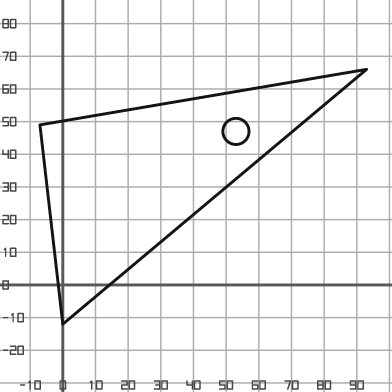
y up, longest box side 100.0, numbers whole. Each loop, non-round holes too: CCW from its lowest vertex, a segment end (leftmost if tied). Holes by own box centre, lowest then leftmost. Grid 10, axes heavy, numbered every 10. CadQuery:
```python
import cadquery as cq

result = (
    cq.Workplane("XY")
    .moveTo(0.0, -12.0)
    .lineTo(93.0, 66.0)
    .lineTo(-7.0, 49.0)
    .close()
    .moveTo(53.0, 47.0)
    .circle(4.0)
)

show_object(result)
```